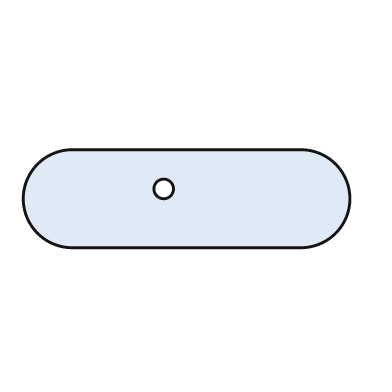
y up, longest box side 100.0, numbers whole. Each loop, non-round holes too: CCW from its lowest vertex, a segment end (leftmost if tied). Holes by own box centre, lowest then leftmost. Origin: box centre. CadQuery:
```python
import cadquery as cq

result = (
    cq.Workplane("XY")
    .moveTo(-35.0, -15.0)
    .lineTo(35.0, -15.0)
    .threePointArc((50.0, 0.0), (35.0, 15.0))
    .lineTo(-35.0, 15.0)
    .threePointArc((-50.0, 0.0), (-35.0, -15.0))
    .close()
    .moveTo(-7.0, 3.0)
    .circle(3.0)
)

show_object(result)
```